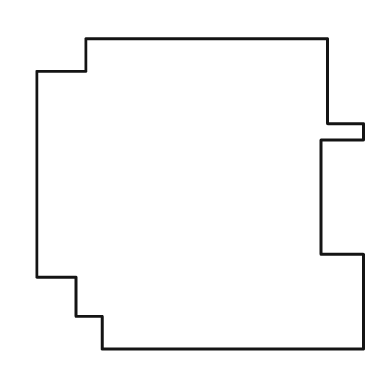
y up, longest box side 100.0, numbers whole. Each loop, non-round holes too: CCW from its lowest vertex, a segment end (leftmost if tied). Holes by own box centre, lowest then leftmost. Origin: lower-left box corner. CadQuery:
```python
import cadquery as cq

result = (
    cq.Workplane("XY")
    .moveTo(20.0, 0.0)
    .lineTo(100.0, 0.0)
    .lineTo(100.0, 29.0)
    .lineTo(87.0, 29.0)
    .lineTo(87.0, 64.0)
    .lineTo(100.0, 64.0)
    .lineTo(100.0, 69.0)
    .lineTo(89.0, 69.0)
    .lineTo(89.0, 95.0)
    .lineTo(15.0, 95.0)
    .lineTo(15.0, 85.0)
    .lineTo(0.0, 85.0)
    .lineTo(0.0, 22.0)
    .lineTo(12.0, 22.0)
    .lineTo(12.0, 10.0)
    .lineTo(20.0, 10.0)
    .close()
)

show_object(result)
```